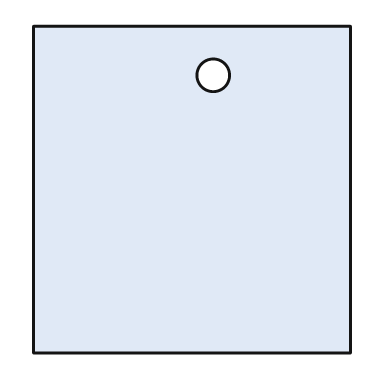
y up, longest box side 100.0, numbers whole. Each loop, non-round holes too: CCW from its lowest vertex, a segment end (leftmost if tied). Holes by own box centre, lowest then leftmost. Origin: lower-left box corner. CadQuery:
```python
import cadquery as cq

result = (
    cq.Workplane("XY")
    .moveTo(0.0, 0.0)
    .lineTo(97.0, 0.0)
    .lineTo(97.0, 100.0)
    .lineTo(0.0, 100.0)
    .close()
    .moveTo(55.0, 85.0)
    .circle(5.0)
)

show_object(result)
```